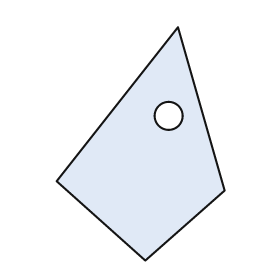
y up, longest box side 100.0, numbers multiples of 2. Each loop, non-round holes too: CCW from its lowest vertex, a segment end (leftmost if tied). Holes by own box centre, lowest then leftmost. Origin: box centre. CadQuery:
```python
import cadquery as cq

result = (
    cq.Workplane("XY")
    .moveTo(2.0, -50.0)
    .lineTo(36.0, -20.0)
    .lineTo(16.0, 50.0)
    .lineTo(-36.0, -16.0)
    .close()
    .moveTo(12.0, 12.0)
    .circle(6.0)
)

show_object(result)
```